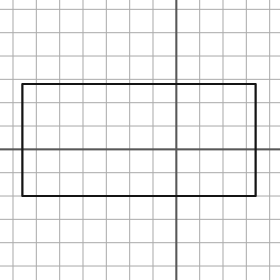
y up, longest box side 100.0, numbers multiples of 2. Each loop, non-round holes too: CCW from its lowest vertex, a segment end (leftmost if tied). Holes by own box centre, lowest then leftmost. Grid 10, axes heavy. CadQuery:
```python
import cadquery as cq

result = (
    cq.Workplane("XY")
    .moveTo(-66.0, -20.0)
    .lineTo(34.0, -20.0)
    .lineTo(34.0, 28.0)
    .lineTo(-66.0, 28.0)
    .close()
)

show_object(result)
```